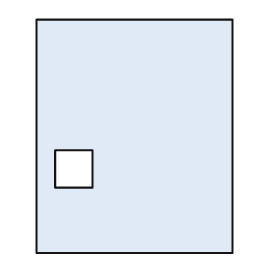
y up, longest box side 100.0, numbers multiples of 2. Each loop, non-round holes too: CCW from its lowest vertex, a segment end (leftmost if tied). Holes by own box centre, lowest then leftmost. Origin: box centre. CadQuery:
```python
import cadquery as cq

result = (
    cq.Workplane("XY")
    .moveTo(-42.0, -50.0)
    .lineTo(42.0, -50.0)
    .lineTo(42.0, 50.0)
    .lineTo(-42.0, 50.0)
    .close()
    .moveTo(-34.0, -22.0)
    .lineTo(-18.0, -22.0)
    .lineTo(-18.0, -6.0)
    .lineTo(-34.0, -6.0)
    .close()
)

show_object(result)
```